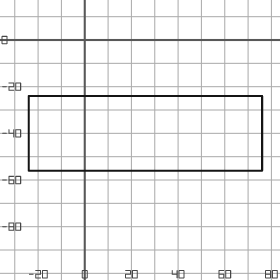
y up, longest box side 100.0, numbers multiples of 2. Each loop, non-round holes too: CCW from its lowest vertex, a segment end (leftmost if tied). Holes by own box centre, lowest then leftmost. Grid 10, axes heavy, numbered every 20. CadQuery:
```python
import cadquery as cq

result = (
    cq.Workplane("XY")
    .moveTo(-24.0, -56.0)
    .lineTo(76.0, -56.0)
    .lineTo(76.0, -24.0)
    .lineTo(-24.0, -24.0)
    .close()
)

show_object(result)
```